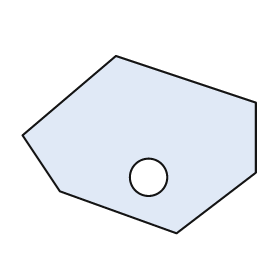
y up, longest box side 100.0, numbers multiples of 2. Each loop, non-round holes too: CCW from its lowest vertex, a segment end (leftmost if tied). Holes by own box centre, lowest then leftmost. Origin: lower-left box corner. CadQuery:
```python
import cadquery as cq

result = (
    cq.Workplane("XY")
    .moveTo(66.0, 0.0)
    .lineTo(100.0, 26.0)
    .lineTo(100.0, 56.0)
    .lineTo(40.0, 76.0)
    .lineTo(0.0, 42.0)
    .lineTo(16.0, 18.0)
    .close()
    .moveTo(54.0, 24.0)
    .circle(8.0)
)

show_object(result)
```